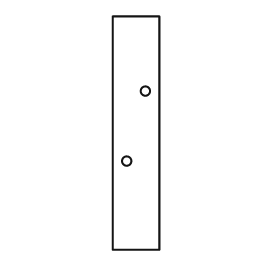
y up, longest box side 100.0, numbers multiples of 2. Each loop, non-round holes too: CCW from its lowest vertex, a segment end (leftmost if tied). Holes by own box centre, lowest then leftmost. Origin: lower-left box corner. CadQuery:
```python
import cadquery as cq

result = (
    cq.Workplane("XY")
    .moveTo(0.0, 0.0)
    .lineTo(20.0, 0.0)
    .lineTo(20.0, 100.0)
    .lineTo(0.0, 100.0)
    .close()
    .moveTo(6.0, 38.0)
    .circle(2.0)
    .moveTo(14.0, 68.0)
    .circle(2.0)
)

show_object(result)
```